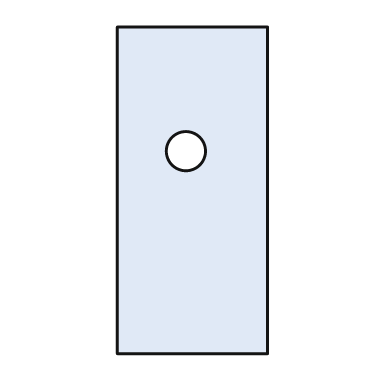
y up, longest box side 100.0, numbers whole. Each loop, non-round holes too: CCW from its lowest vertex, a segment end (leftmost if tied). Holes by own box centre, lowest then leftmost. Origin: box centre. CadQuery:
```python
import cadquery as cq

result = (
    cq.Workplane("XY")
    .moveTo(-23.0, -50.0)
    .lineTo(23.0, -50.0)
    .lineTo(23.0, 50.0)
    .lineTo(-23.0, 50.0)
    .close()
    .moveTo(-2.0, 12.0)
    .circle(6.0)
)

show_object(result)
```